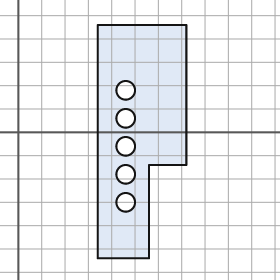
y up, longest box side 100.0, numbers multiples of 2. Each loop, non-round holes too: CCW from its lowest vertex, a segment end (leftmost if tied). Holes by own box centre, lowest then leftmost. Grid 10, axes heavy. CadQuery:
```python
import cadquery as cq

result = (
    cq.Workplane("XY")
    .moveTo(34.0, -54.0)
    .lineTo(56.0, -54.0)
    .lineTo(56.0, -14.0)
    .lineTo(72.0, -14.0)
    .lineTo(72.0, 46.0)
    .lineTo(34.0, 46.0)
    .close()
    .moveTo(46.0, -30.0)
    .circle(4.0)
    .moveTo(46.0, -18.0)
    .circle(4.0)
    .moveTo(46.0, -6.0)
    .circle(4.0)
    .moveTo(46.0, 6.0)
    .circle(4.0)
    .moveTo(46.0, 18.0)
    .circle(4.0)
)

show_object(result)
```